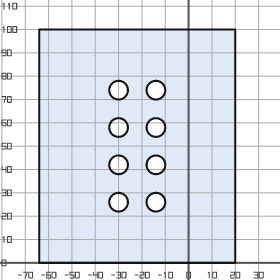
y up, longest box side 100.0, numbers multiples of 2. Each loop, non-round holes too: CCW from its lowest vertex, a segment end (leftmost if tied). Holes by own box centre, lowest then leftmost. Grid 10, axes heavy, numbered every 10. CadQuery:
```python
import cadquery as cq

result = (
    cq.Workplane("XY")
    .moveTo(-64.0, 0.0)
    .lineTo(20.0, 0.0)
    .lineTo(20.0, 100.0)
    .lineTo(-64.0, 100.0)
    .close()
    .moveTo(-30.0, 26.0)
    .circle(4.0)
    .moveTo(-14.0, 26.0)
    .circle(4.0)
    .moveTo(-30.0, 42.0)
    .circle(4.0)
    .moveTo(-14.0, 42.0)
    .circle(4.0)
    .moveTo(-30.0, 58.0)
    .circle(4.0)
    .moveTo(-14.0, 58.0)
    .circle(4.0)
    .moveTo(-30.0, 74.0)
    .circle(4.0)
    .moveTo(-14.0, 74.0)
    .circle(4.0)
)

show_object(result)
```